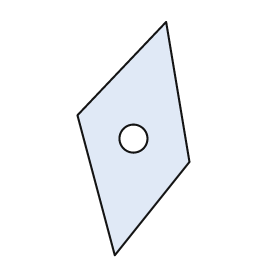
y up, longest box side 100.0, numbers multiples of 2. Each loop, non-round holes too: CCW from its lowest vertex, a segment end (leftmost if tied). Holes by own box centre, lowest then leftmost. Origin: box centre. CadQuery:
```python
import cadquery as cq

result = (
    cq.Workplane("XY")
    .moveTo(-8.0, -50.0)
    .lineTo(24.0, -10.0)
    .lineTo(14.0, 50.0)
    .lineTo(-24.0, 10.0)
    .close()
    .moveTo(0.0, 0.0)
    .circle(6.0)
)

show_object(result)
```